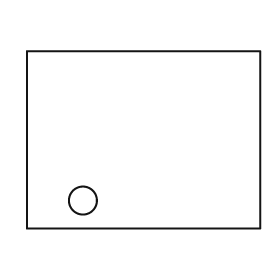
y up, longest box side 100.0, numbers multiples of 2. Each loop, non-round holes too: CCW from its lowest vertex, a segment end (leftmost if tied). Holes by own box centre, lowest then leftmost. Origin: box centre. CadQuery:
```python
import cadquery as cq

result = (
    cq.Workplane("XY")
    .moveTo(-50.0, -38.0)
    .lineTo(50.0, -38.0)
    .lineTo(50.0, 38.0)
    .lineTo(-50.0, 38.0)
    .close()
    .moveTo(-26.0, -26.0)
    .circle(6.0)
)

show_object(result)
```